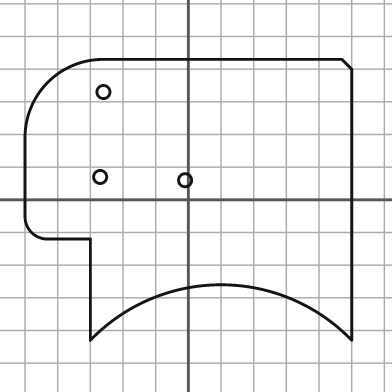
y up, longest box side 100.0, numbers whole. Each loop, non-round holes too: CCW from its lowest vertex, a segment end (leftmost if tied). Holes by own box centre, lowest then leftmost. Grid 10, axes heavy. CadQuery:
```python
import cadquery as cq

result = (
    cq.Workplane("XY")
    .moveTo(-30.0, -43.0)
    .threePointArc((10.0, -26.0), (50.0, -43.0))
    .lineTo(50.0, 40.0)
    .lineTo(47.0, 43.0)
    .lineTo(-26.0, 43.0)
    .threePointArc((-43.0, 36.0), (-50.0, 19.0))
    .lineTo(-50.0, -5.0)
    .threePointArc((-48.0, -10.0), (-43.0, -12.0))
    .lineTo(-30.0, -12.0)
    .close()
    .moveTo(-1.0, 6.0)
    .circle(2.0)
    .moveTo(-27.0, 7.0)
    .circle(2.0)
    .moveTo(-26.0, 33.0)
    .circle(2.0)
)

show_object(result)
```